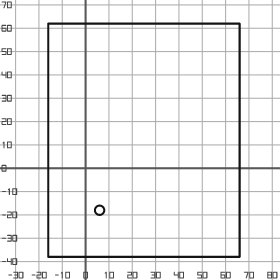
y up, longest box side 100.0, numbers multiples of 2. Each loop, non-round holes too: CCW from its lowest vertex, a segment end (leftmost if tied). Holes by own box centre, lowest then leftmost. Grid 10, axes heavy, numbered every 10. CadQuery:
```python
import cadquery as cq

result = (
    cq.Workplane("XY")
    .moveTo(-16.0, -38.0)
    .lineTo(66.0, -38.0)
    .lineTo(66.0, 62.0)
    .lineTo(-16.0, 62.0)
    .close()
    .moveTo(6.0, -18.0)
    .circle(2.0)
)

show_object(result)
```